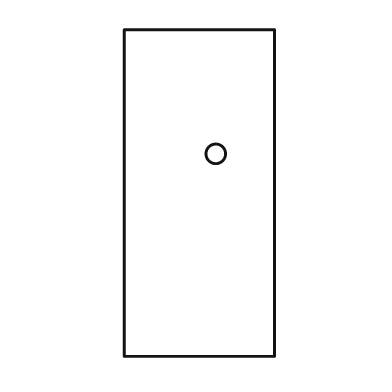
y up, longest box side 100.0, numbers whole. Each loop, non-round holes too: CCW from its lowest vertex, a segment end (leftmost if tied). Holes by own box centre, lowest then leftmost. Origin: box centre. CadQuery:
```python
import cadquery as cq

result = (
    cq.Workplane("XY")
    .moveTo(-23.0, -50.0)
    .lineTo(23.0, -50.0)
    .lineTo(23.0, 50.0)
    .lineTo(-23.0, 50.0)
    .close()
    .moveTo(5.0, 12.0)
    .circle(3.0)
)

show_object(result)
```